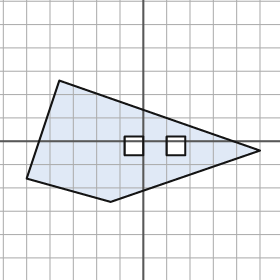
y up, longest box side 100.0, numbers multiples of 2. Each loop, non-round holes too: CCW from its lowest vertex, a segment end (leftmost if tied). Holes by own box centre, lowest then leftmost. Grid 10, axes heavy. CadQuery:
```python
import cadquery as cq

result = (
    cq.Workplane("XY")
    .moveTo(-14.0, -26.0)
    .lineTo(50.0, -4.0)
    .lineTo(-36.0, 26.0)
    .lineTo(-50.0, -16.0)
    .close()
    .moveTo(-8.0, -6.0)
    .lineTo(0.0, -6.0)
    .lineTo(0.0, 2.0)
    .lineTo(-8.0, 2.0)
    .close()
    .moveTo(10.0, -6.0)
    .lineTo(18.0, -6.0)
    .lineTo(18.0, 2.0)
    .lineTo(10.0, 2.0)
    .close()
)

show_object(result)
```